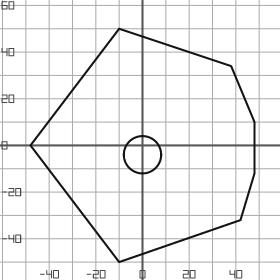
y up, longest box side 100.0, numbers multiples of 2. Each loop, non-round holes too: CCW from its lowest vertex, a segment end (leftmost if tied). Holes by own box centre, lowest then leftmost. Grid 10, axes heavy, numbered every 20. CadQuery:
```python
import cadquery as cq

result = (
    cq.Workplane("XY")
    .moveTo(-10.0, -50.0)
    .lineTo(42.0, -32.0)
    .lineTo(48.0, -12.0)
    .lineTo(48.0, 10.0)
    .lineTo(38.0, 34.0)
    .lineTo(-10.0, 50.0)
    .lineTo(-48.0, 0.0)
    .close()
    .moveTo(0.0, -4.0)
    .circle(8.0)
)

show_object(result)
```